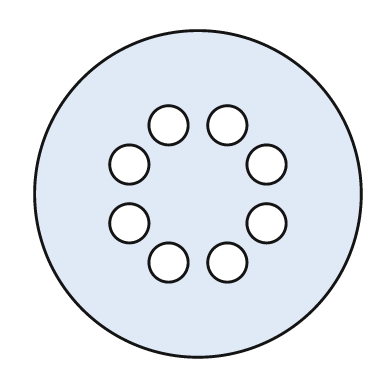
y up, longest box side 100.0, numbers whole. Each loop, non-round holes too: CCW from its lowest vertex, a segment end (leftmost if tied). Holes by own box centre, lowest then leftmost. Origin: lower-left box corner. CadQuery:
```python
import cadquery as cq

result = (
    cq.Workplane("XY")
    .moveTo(50.0, 50.0)
    .circle(50.0)
    .moveTo(41.0, 29.0)
    .circle(6.0)
    .moveTo(59.0, 29.0)
    .circle(6.0)
    .moveTo(29.0, 41.0)
    .circle(6.0)
    .moveTo(71.0, 41.0)
    .circle(6.0)
    .moveTo(29.0, 59.0)
    .circle(6.0)
    .moveTo(71.0, 59.0)
    .circle(6.0)
    .moveTo(41.0, 71.0)
    .circle(6.0)
    .moveTo(59.0, 71.0)
    .circle(6.0)
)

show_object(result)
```